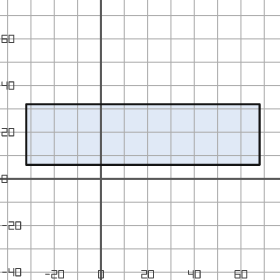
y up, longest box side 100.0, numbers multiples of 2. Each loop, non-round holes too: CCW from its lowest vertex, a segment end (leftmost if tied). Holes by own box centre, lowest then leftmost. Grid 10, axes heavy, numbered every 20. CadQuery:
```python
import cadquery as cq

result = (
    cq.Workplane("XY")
    .moveTo(-32.0, 6.0)
    .lineTo(68.0, 6.0)
    .lineTo(68.0, 32.0)
    .lineTo(-32.0, 32.0)
    .close()
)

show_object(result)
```